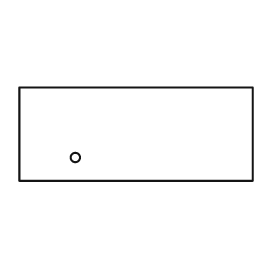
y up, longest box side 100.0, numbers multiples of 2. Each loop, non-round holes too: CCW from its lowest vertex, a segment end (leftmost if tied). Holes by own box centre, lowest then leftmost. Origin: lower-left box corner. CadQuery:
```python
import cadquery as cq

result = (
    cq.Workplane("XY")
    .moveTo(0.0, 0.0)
    .lineTo(100.0, 0.0)
    .lineTo(100.0, 40.0)
    .lineTo(0.0, 40.0)
    .close()
    .moveTo(24.0, 10.0)
    .circle(2.0)
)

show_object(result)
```